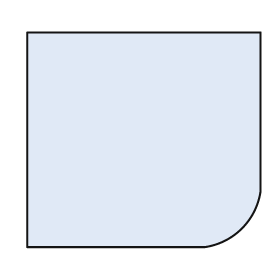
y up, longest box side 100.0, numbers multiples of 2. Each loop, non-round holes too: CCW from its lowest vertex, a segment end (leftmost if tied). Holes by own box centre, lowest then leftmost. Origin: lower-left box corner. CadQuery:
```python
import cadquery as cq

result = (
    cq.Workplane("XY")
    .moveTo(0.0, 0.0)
    .lineTo(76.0, 0.0)
    .threePointArc((92.0, 8.0), (100.0, 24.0))
    .lineTo(100.0, 92.0)
    .lineTo(0.0, 92.0)
    .close()
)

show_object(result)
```